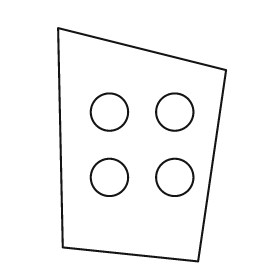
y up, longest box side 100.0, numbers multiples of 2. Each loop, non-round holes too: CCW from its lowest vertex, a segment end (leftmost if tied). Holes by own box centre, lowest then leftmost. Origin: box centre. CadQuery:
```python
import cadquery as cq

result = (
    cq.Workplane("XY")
    .moveTo(24.0, -50.0)
    .lineTo(36.0, 32.0)
    .lineTo(-36.0, 50.0)
    .lineTo(-34.0, -44.0)
    .close()
    .moveTo(-14.0, -14.0)
    .circle(8.0)
    .moveTo(14.0, -14.0)
    .circle(8.0)
    .moveTo(-14.0, 14.0)
    .circle(8.0)
    .moveTo(14.0, 14.0)
    .circle(8.0)
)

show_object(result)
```